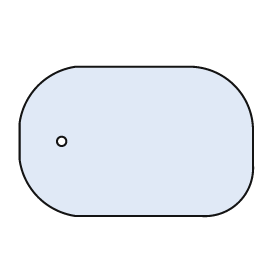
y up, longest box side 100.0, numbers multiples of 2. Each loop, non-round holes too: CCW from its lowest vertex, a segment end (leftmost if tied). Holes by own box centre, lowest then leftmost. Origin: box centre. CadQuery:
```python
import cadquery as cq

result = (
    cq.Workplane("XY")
    .moveTo(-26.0, -32.0)
    .lineTo(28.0, -32.0)
    .threePointArc((44.0, -26.0), (50.0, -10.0))
    .lineTo(50.0, 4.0)
    .threePointArc((42.0, 24.0), (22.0, 32.0))
    .lineTo(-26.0, 32.0)
    .threePointArc((-42.0, 24.0), (-50.0, 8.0))
    .lineTo(-50.0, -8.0)
    .threePointArc((-42.0, -24.0), (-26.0, -32.0))
    .close()
    .moveTo(-32.0, 0.0)
    .circle(2.0)
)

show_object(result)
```